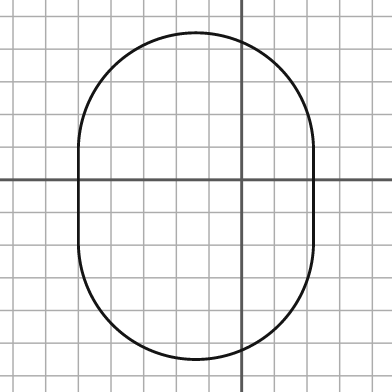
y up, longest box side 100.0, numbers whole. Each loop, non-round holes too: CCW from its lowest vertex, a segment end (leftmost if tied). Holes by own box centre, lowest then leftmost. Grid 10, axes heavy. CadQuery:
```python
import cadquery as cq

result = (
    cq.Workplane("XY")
    .moveTo(-50.0, -19.0)
    .threePointArc((-14.0, -55.0), (22.0, -19.0))
    .lineTo(22.0, 9.0)
    .threePointArc((-14.0, 45.0), (-50.0, 9.0))
    .close()
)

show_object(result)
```